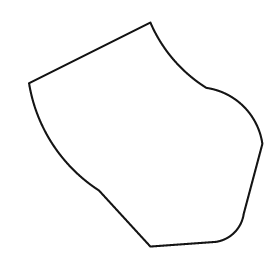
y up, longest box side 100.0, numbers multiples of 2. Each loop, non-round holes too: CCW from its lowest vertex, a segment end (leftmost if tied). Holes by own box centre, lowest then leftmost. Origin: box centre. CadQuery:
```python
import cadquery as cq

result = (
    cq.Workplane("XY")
    .moveTo(2.0, -48.0)
    .lineTo(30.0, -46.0)
    .threePointArc((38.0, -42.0), (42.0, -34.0))
    .lineTo(50.0, -4.0)
    .threePointArc((42.0, 12.0), (26.0, 20.0))
    .threePointArc((12.0, 32.0), (2.0, 48.0))
    .lineTo(-50.0, 22.0)
    .threePointArc((-40.0, -4.0), (-20.0, -24.0))
    .close()
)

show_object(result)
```